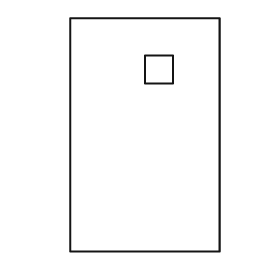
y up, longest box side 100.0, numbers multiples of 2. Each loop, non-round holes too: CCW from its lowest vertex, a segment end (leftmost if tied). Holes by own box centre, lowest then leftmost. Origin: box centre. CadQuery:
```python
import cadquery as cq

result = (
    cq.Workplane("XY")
    .moveTo(-32.0, -50.0)
    .lineTo(32.0, -50.0)
    .lineTo(32.0, 50.0)
    .lineTo(-32.0, 50.0)
    .close()
    .moveTo(0.0, 22.0)
    .lineTo(12.0, 22.0)
    .lineTo(12.0, 34.0)
    .lineTo(0.0, 34.0)
    .close()
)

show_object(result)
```